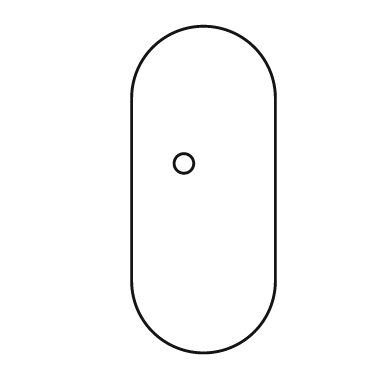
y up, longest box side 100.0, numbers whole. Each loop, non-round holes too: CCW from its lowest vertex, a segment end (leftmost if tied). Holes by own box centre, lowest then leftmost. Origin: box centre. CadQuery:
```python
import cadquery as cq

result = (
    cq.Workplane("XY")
    .moveTo(-22.0, -28.0)
    .threePointArc((0.0, -50.0), (22.0, -28.0))
    .lineTo(22.0, 28.0)
    .threePointArc((0.0, 50.0), (-22.0, 28.0))
    .close()
    .moveTo(-6.0, 8.0)
    .circle(3.0)
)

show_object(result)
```